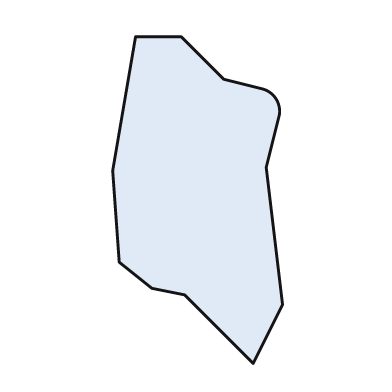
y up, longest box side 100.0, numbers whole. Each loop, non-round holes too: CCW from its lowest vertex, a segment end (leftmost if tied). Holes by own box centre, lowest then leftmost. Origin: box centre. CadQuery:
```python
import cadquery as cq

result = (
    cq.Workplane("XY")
    .moveTo(17.0, -50.0)
    .lineTo(26.0, -32.0)
    .lineTo(21.0, 10.0)
    .lineTo(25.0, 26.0)
    .threePointArc((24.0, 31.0), (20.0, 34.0))
    .lineTo(8.0, 37.0)
    .lineTo(-5.0, 50.0)
    .lineTo(-19.0, 50.0)
    .lineTo(-26.0, 9.0)
    .lineTo(-24.0, -19.0)
    .lineTo(-14.0, -27.0)
    .lineTo(-4.0, -29.0)
    .close()
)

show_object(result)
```